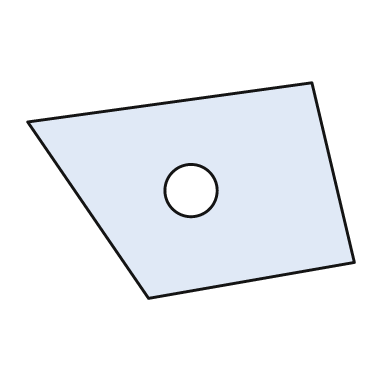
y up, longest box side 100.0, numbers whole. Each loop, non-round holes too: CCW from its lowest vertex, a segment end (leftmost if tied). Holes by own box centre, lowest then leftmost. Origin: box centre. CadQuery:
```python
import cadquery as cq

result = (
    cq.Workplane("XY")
    .moveTo(-13.0, -33.0)
    .lineTo(50.0, -22.0)
    .lineTo(37.0, 33.0)
    .lineTo(-50.0, 21.0)
    .close()
    .moveTo(0.0, 0.0)
    .circle(8.0)
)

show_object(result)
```